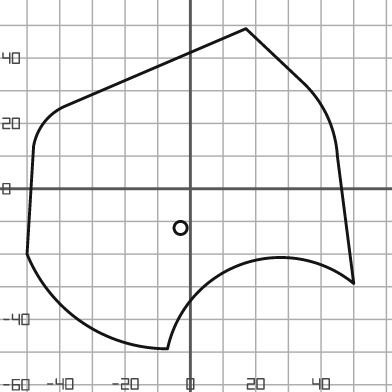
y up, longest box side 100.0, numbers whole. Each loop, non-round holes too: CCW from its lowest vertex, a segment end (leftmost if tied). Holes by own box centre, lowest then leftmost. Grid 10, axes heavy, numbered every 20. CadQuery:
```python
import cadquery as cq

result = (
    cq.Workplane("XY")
    .moveTo(-7.0, -49.0)
    .threePointArc((16.0, -23.0), (50.0, -29.0))
    .lineTo(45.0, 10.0)
    .threePointArc((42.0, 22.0), (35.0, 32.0))
    .lineTo(17.0, 49.0)
    .lineTo(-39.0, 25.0)
    .threePointArc((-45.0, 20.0), (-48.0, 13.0))
    .lineTo(-50.0, -20.0)
    .threePointArc((-33.0, -41.0), (-7.0, -49.0))
    .close()
    .moveTo(-3.0, -12.0)
    .circle(2.0)
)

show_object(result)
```